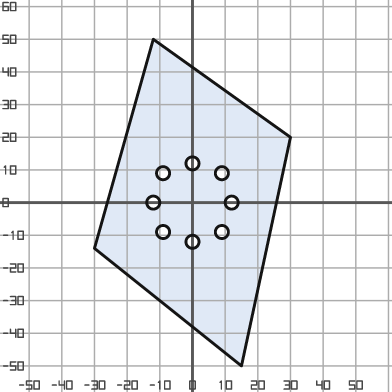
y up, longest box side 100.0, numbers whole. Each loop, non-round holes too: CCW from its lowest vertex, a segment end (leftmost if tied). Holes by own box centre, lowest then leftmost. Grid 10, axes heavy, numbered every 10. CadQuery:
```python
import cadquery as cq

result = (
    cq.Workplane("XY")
    .moveTo(15.0, -50.0)
    .lineTo(30.0, 20.0)
    .lineTo(-12.0, 50.0)
    .lineTo(-30.0, -14.0)
    .close()
    .moveTo(0.0, -12.0)
    .circle(2.0)
    .moveTo(-9.0, -9.0)
    .circle(2.0)
    .moveTo(9.0, -9.0)
    .circle(2.0)
    .moveTo(-12.0, 0.0)
    .circle(2.0)
    .moveTo(12.0, 0.0)
    .circle(2.0)
    .moveTo(-9.0, 9.0)
    .circle(2.0)
    .moveTo(9.0, 9.0)
    .circle(2.0)
    .moveTo(0.0, 12.0)
    .circle(2.0)
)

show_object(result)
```